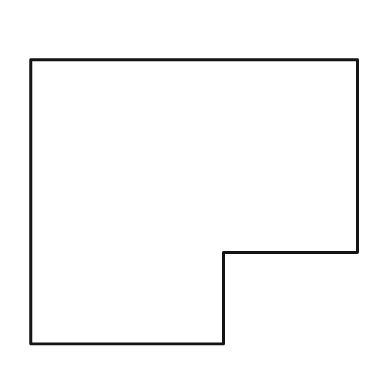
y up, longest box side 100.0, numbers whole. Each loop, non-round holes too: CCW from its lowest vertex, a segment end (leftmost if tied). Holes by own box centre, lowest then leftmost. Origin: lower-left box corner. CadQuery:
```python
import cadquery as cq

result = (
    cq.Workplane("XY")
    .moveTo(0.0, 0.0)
    .lineTo(59.0, 0.0)
    .lineTo(59.0, 28.0)
    .lineTo(100.0, 28.0)
    .lineTo(100.0, 87.0)
    .lineTo(0.0, 87.0)
    .close()
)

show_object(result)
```